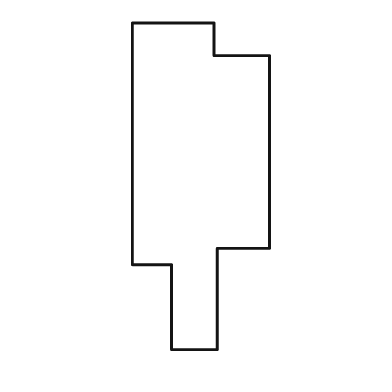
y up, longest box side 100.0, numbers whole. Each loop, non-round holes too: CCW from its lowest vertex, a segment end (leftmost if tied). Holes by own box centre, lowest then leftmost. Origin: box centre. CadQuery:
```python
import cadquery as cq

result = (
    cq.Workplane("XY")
    .moveTo(-9.0, -50.0)
    .lineTo(5.0, -50.0)
    .lineTo(5.0, -19.0)
    .lineTo(21.0, -19.0)
    .lineTo(21.0, 40.0)
    .lineTo(4.0, 40.0)
    .lineTo(4.0, 50.0)
    .lineTo(-21.0, 50.0)
    .lineTo(-21.0, -24.0)
    .lineTo(-9.0, -24.0)
    .close()
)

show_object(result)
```